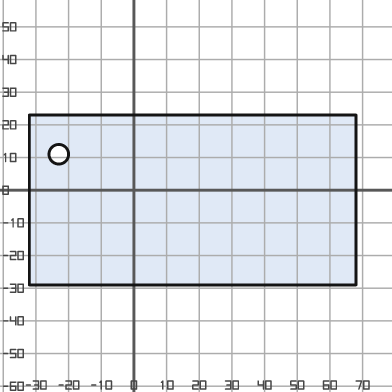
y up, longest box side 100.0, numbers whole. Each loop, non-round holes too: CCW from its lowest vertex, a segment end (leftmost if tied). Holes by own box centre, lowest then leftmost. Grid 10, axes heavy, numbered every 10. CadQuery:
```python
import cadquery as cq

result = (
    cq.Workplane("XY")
    .moveTo(-32.0, -29.0)
    .lineTo(68.0, -29.0)
    .lineTo(68.0, 23.0)
    .lineTo(-32.0, 23.0)
    .close()
    .moveTo(-23.0, 11.0)
    .circle(3.0)
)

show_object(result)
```